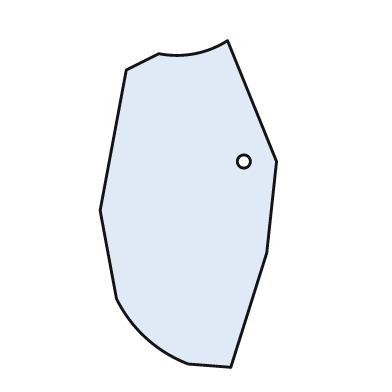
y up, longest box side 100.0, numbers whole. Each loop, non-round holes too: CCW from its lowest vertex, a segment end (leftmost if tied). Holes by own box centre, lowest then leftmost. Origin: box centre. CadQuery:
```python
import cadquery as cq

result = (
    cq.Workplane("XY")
    .moveTo(13.0, -50.0)
    .lineTo(24.0, -15.0)
    .lineTo(27.0, 13.0)
    .lineTo(12.0, 50.0)
    .threePointArc((2.0, 46.0), (-9.0, 46.0))
    .lineTo(-19.0, 41.0)
    .lineTo(-27.0, -2.0)
    .lineTo(-22.0, -29.0)
    .threePointArc((-13.0, -41.0), (0.0, -49.0))
    .close()
    .moveTo(17.0, 13.0)
    .circle(2.0)
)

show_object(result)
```